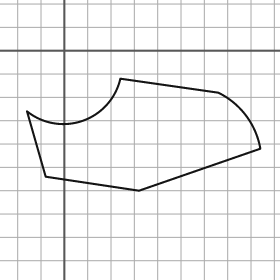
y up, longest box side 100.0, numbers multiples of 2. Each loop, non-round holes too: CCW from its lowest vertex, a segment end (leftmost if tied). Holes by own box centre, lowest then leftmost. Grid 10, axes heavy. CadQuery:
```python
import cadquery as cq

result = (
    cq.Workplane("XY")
    .moveTo(32.0, -60.0)
    .lineTo(84.0, -42.0)
    .threePointArc((78.0, -28.0), (66.0, -18.0))
    .lineTo(24.0, -12.0)
    .threePointArc((8.0, -30.0), (-16.0, -26.0))
    .lineTo(-8.0, -54.0)
    .close()
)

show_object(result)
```